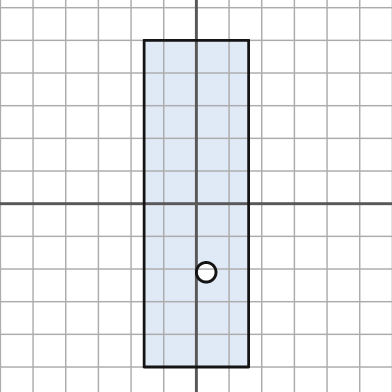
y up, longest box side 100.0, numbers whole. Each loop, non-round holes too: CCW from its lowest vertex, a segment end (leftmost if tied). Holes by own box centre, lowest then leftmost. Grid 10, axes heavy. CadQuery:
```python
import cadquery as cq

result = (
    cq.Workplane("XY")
    .moveTo(-16.0, -50.0)
    .lineTo(16.0, -50.0)
    .lineTo(16.0, 50.0)
    .lineTo(-16.0, 50.0)
    .close()
    .moveTo(3.0, -21.0)
    .circle(3.0)
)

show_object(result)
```